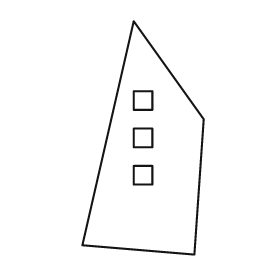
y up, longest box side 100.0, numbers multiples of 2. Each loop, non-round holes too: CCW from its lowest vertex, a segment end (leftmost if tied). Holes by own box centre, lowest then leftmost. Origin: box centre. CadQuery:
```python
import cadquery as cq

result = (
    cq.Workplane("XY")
    .moveTo(22.0, -50.0)
    .lineTo(26.0, 8.0)
    .lineTo(-4.0, 50.0)
    .lineTo(-26.0, -46.0)
    .close()
    .moveTo(-4.0, -20.0)
    .lineTo(4.0, -20.0)
    .lineTo(4.0, -12.0)
    .lineTo(-4.0, -12.0)
    .close()
    .moveTo(-4.0, -4.0)
    .lineTo(4.0, -4.0)
    .lineTo(4.0, 4.0)
    .lineTo(-4.0, 4.0)
    .close()
    .moveTo(-4.0, 12.0)
    .lineTo(4.0, 12.0)
    .lineTo(4.0, 20.0)
    .lineTo(-4.0, 20.0)
    .close()
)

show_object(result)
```